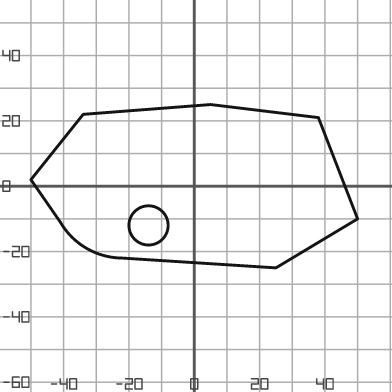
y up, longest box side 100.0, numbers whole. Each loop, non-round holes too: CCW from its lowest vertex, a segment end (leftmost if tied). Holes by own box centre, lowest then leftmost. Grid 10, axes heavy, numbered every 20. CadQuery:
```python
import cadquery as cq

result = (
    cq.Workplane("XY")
    .moveTo(25.0, -25.0)
    .lineTo(50.0, -10.0)
    .lineTo(38.0, 21.0)
    .lineTo(5.0, 25.0)
    .lineTo(-34.0, 22.0)
    .lineTo(-50.0, 2.0)
    .lineTo(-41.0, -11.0)
    .threePointArc((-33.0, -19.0), (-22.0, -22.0))
    .close()
    .moveTo(-14.0, -12.0)
    .circle(6.0)
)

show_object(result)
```